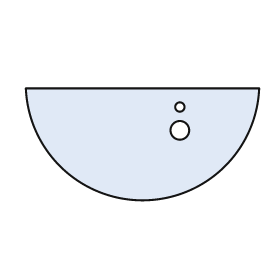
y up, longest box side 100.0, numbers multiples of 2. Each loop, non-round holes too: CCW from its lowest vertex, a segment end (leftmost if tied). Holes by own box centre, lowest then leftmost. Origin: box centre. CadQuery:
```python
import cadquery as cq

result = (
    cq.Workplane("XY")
    .moveTo(-50.0, 24.0)
    .threePointArc((0.0, -24.0), (50.0, 24.0))
    .close()
    .moveTo(16.0, 6.0)
    .circle(4.0)
    .moveTo(16.0, 16.0)
    .circle(2.0)
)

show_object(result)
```